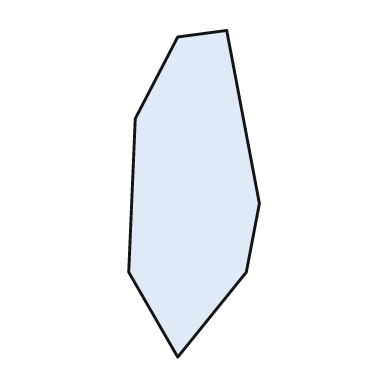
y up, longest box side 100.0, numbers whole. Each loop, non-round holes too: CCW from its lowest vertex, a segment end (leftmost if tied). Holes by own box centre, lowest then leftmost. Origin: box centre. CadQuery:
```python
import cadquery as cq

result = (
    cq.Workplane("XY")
    .moveTo(-5.0, -50.0)
    .lineTo(16.0, -24.0)
    .lineTo(20.0, -3.0)
    .lineTo(10.0, 50.0)
    .lineTo(-5.0, 48.0)
    .lineTo(-18.0, 23.0)
    .lineTo(-20.0, -24.0)
    .close()
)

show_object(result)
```